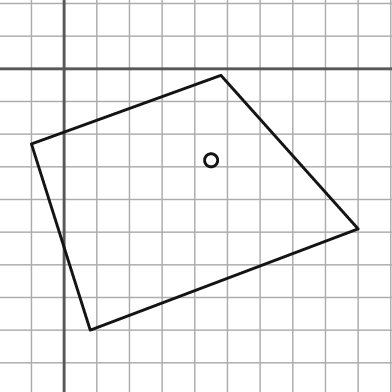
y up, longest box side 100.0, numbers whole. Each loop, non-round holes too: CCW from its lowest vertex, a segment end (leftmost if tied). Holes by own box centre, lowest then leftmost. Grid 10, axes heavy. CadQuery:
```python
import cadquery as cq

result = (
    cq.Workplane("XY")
    .moveTo(8.0, -80.0)
    .lineTo(90.0, -49.0)
    .lineTo(48.0, -2.0)
    .lineTo(-10.0, -23.0)
    .close()
    .moveTo(45.0, -28.0)
    .circle(2.0)
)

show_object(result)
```